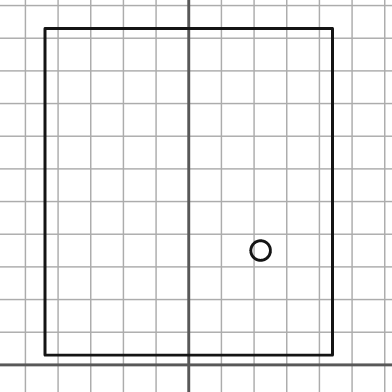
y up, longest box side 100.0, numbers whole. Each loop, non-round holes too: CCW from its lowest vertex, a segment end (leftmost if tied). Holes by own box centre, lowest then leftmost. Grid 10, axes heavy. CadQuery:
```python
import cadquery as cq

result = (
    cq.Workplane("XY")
    .moveTo(-44.0, 3.0)
    .lineTo(44.0, 3.0)
    .lineTo(44.0, 103.0)
    .lineTo(-44.0, 103.0)
    .close()
    .moveTo(22.0, 35.0)
    .circle(3.0)
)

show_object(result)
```